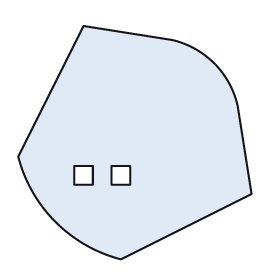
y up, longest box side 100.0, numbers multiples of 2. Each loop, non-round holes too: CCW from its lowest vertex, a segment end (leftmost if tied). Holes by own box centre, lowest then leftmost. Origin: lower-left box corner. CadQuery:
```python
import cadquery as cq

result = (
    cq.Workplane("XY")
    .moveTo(44.0, 0.0)
    .lineTo(100.0, 28.0)
    .lineTo(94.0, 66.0)
    .threePointArc((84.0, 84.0), (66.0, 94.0))
    .lineTo(28.0, 100.0)
    .lineTo(0.0, 44.0)
    .threePointArc((16.0, 16.0), (44.0, 0.0))
    .close()
    .moveTo(24.0, 32.0)
    .lineTo(32.0, 32.0)
    .lineTo(32.0, 40.0)
    .lineTo(24.0, 40.0)
    .close()
    .moveTo(40.0, 32.0)
    .lineTo(48.0, 32.0)
    .lineTo(48.0, 40.0)
    .lineTo(40.0, 40.0)
    .close()
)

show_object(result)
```